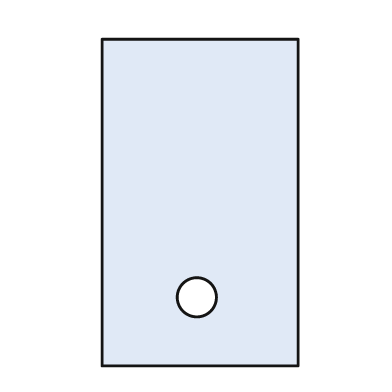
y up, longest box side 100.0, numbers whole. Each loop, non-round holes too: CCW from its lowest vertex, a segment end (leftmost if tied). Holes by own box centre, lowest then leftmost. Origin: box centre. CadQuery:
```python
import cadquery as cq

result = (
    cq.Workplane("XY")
    .moveTo(-30.0, -50.0)
    .lineTo(30.0, -50.0)
    .lineTo(30.0, 50.0)
    .lineTo(-30.0, 50.0)
    .close()
    .moveTo(-1.0, -29.0)
    .circle(6.0)
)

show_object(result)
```